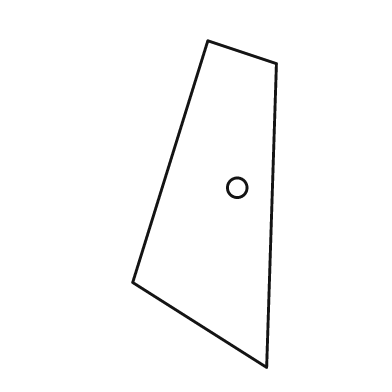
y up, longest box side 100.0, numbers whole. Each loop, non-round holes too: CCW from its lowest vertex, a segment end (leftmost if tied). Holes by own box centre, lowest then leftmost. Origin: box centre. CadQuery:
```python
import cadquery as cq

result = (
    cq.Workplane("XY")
    .moveTo(19.0, -50.0)
    .lineTo(22.0, 43.0)
    .lineTo(1.0, 50.0)
    .lineTo(-22.0, -24.0)
    .close()
    .moveTo(10.0, 5.0)
    .circle(3.0)
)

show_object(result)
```